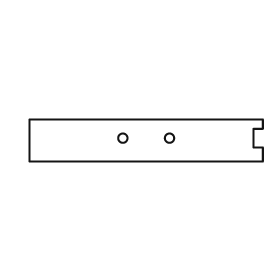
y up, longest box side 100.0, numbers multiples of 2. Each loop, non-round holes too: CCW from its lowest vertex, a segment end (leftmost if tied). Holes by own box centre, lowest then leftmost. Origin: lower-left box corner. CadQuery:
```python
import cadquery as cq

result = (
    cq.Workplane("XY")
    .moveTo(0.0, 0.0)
    .lineTo(100.0, 0.0)
    .lineTo(100.0, 6.0)
    .lineTo(96.0, 6.0)
    .lineTo(96.0, 14.0)
    .lineTo(100.0, 14.0)
    .lineTo(100.0, 18.0)
    .lineTo(0.0, 18.0)
    .close()
    .moveTo(40.0, 10.0)
    .circle(2.0)
    .moveTo(60.0, 10.0)
    .circle(2.0)
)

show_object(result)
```